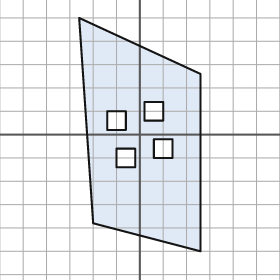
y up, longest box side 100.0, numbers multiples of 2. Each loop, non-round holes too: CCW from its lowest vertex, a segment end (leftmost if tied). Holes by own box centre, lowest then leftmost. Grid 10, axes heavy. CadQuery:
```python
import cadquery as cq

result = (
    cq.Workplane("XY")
    .moveTo(26.0, -50.0)
    .lineTo(26.0, 26.0)
    .lineTo(-26.0, 50.0)
    .lineTo(-20.0, -38.0)
    .close()
    .moveTo(-10.0, -14.0)
    .lineTo(-2.0, -14.0)
    .lineTo(-2.0, -6.0)
    .lineTo(-10.0, -6.0)
    .close()
    .moveTo(6.0, -10.0)
    .lineTo(14.0, -10.0)
    .lineTo(14.0, -2.0)
    .lineTo(6.0, -2.0)
    .close()
    .moveTo(-14.0, 2.0)
    .lineTo(-6.0, 2.0)
    .lineTo(-6.0, 10.0)
    .lineTo(-14.0, 10.0)
    .close()
    .moveTo(2.0, 6.0)
    .lineTo(10.0, 6.0)
    .lineTo(10.0, 14.0)
    .lineTo(2.0, 14.0)
    .close()
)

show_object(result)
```